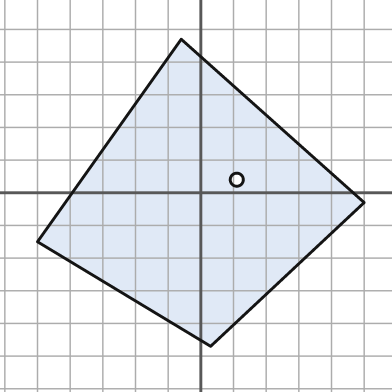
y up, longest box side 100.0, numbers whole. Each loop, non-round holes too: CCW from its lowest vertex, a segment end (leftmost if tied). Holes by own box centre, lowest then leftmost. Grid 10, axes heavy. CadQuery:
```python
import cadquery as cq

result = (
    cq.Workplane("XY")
    .moveTo(3.0, -47.0)
    .lineTo(50.0, -3.0)
    .lineTo(-6.0, 47.0)
    .lineTo(-50.0, -15.0)
    .close()
    .moveTo(11.0, 4.0)
    .circle(2.0)
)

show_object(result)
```